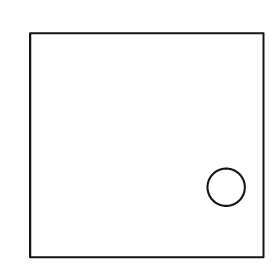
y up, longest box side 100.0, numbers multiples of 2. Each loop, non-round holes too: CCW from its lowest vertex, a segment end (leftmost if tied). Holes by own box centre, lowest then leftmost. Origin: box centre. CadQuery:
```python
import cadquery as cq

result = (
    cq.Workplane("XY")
    .moveTo(-50.0, -48.0)
    .lineTo(50.0, -48.0)
    .lineTo(50.0, 48.0)
    .lineTo(-50.0, 48.0)
    .close()
    .moveTo(34.0, -18.0)
    .circle(8.0)
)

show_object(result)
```